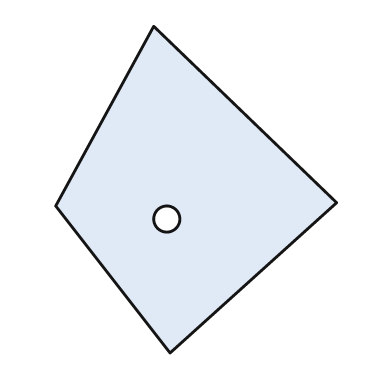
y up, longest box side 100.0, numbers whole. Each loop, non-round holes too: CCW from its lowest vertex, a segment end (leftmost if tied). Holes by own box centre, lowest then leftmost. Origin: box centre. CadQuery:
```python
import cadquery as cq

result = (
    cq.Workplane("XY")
    .moveTo(-8.0, -50.0)
    .lineTo(43.0, -4.0)
    .lineTo(-13.0, 50.0)
    .lineTo(-43.0, -5.0)
    .close()
    .moveTo(-9.0, -9.0)
    .circle(4.0)
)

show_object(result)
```